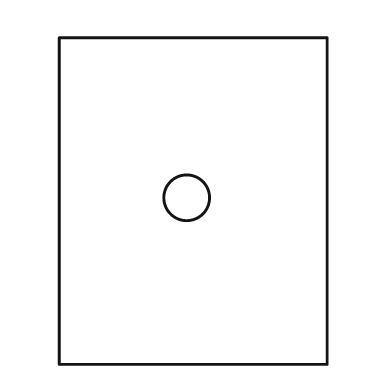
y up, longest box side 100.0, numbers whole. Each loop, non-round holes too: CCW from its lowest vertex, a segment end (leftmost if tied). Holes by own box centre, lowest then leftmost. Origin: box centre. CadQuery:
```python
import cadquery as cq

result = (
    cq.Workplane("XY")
    .moveTo(-41.0, -50.0)
    .lineTo(41.0, -50.0)
    .lineTo(41.0, 50.0)
    .lineTo(-41.0, 50.0)
    .close()
    .moveTo(-2.0, 1.0)
    .circle(7.0)
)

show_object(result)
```